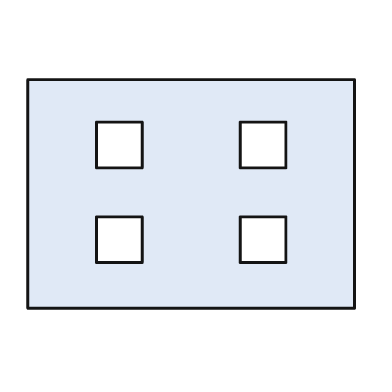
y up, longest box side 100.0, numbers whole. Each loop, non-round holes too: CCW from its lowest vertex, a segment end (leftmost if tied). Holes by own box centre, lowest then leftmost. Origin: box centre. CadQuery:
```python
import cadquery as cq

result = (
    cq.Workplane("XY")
    .moveTo(-50.0, -35.0)
    .lineTo(50.0, -35.0)
    .lineTo(50.0, 35.0)
    .lineTo(-50.0, 35.0)
    .close()
    .moveTo(-29.0, -21.0)
    .lineTo(-15.0, -21.0)
    .lineTo(-15.0, -7.0)
    .lineTo(-29.0, -7.0)
    .close()
    .moveTo(15.0, -21.0)
    .lineTo(29.0, -21.0)
    .lineTo(29.0, -7.0)
    .lineTo(15.0, -7.0)
    .close()
    .moveTo(-29.0, 8.0)
    .lineTo(-15.0, 8.0)
    .lineTo(-15.0, 22.0)
    .lineTo(-29.0, 22.0)
    .close()
    .moveTo(15.0, 8.0)
    .lineTo(29.0, 8.0)
    .lineTo(29.0, 22.0)
    .lineTo(15.0, 22.0)
    .close()
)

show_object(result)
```